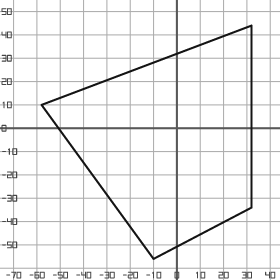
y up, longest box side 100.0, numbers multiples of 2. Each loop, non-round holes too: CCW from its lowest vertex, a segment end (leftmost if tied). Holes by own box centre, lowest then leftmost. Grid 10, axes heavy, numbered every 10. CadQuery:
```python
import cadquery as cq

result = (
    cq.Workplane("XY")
    .moveTo(-10.0, -56.0)
    .lineTo(32.0, -34.0)
    .lineTo(32.0, 44.0)
    .lineTo(-58.0, 10.0)
    .close()
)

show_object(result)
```